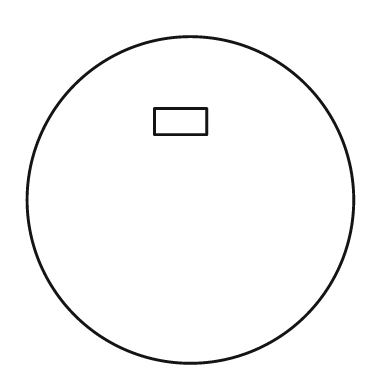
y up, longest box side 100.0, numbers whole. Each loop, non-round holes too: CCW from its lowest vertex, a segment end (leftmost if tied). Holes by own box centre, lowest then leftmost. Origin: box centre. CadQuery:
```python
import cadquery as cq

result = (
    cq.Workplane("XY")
    .moveTo(0.0, 0.0)
    .circle(50.0)
    .moveTo(-11.0, 20.0)
    .lineTo(5.0, 20.0)
    .lineTo(5.0, 28.0)
    .lineTo(-11.0, 28.0)
    .close()
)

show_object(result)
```